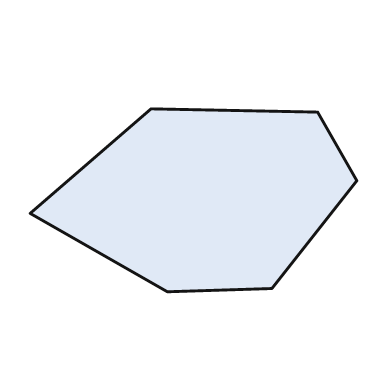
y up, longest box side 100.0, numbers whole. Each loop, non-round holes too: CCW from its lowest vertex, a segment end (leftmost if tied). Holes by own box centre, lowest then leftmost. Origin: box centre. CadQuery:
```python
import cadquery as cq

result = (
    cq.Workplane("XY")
    .moveTo(-8.0, -28.0)
    .lineTo(24.0, -27.0)
    .lineTo(50.0, 6.0)
    .lineTo(38.0, 27.0)
    .lineTo(-13.0, 28.0)
    .lineTo(-50.0, -4.0)
    .close()
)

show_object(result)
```